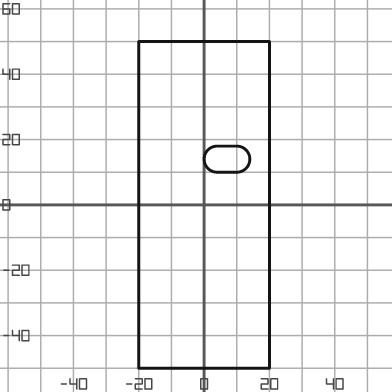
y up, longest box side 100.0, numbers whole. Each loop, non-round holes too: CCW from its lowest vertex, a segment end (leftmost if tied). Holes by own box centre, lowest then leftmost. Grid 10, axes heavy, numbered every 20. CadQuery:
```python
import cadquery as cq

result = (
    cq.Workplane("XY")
    .moveTo(-20.0, -50.0)
    .lineTo(20.0, -50.0)
    .lineTo(20.0, 50.0)
    .lineTo(-20.0, 50.0)
    .close()
    .moveTo(4.0, 10.0)
    .lineTo(10.0, 10.0)
    .threePointArc((14.0, 14.0), (10.0, 18.0))
    .lineTo(4.0, 18.0)
    .threePointArc((0.0, 14.0), (4.0, 10.0))
    .close()
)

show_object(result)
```